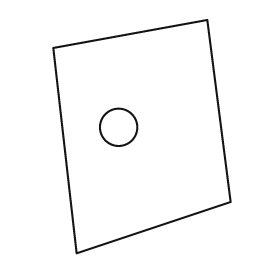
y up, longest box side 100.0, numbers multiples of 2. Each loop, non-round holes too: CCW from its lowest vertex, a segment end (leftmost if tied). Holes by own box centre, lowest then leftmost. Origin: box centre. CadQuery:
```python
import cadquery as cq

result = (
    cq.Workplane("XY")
    .moveTo(-28.0, -50.0)
    .lineTo(38.0, -28.0)
    .lineTo(28.0, 50.0)
    .lineTo(-38.0, 38.0)
    .close()
    .moveTo(-10.0, 4.0)
    .circle(8.0)
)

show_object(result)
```